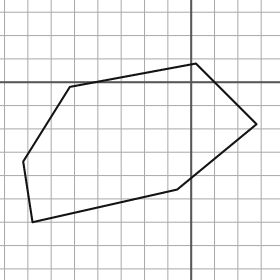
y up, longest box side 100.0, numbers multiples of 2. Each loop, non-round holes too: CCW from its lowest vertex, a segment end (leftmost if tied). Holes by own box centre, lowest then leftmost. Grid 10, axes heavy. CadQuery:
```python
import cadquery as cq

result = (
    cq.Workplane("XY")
    .moveTo(-68.0, -60.0)
    .lineTo(-6.0, -46.0)
    .lineTo(28.0, -18.0)
    .lineTo(2.0, 8.0)
    .lineTo(-52.0, -2.0)
    .lineTo(-72.0, -34.0)
    .close()
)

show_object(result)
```